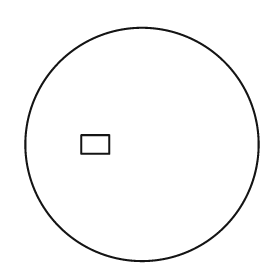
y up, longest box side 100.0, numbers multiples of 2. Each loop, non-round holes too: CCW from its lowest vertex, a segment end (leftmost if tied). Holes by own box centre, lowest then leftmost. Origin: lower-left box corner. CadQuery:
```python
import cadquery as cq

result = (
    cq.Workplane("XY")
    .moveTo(50.0, 50.0)
    .circle(50.0)
    .moveTo(24.0, 46.0)
    .lineTo(36.0, 46.0)
    .lineTo(36.0, 54.0)
    .lineTo(24.0, 54.0)
    .close()
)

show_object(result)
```